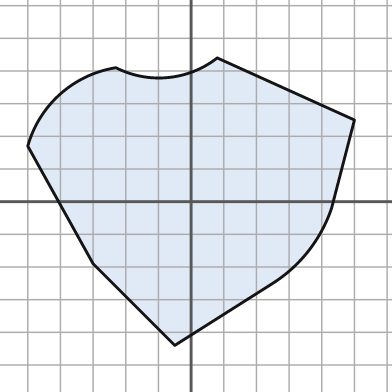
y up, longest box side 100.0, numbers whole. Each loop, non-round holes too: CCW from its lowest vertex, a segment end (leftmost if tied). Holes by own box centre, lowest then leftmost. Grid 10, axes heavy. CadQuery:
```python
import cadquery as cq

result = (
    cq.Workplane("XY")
    .moveTo(-5.0, -44.0)
    .lineTo(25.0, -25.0)
    .threePointArc((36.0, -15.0), (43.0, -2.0))
    .lineTo(50.0, 25.0)
    .lineTo(8.0, 44.0)
    .threePointArc((-7.0, 38.0), (-23.0, 41.0))
    .threePointArc((-40.0, 33.0), (-50.0, 17.0))
    .lineTo(-30.0, -19.0)
    .close()
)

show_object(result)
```